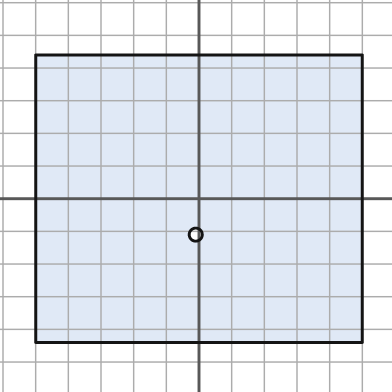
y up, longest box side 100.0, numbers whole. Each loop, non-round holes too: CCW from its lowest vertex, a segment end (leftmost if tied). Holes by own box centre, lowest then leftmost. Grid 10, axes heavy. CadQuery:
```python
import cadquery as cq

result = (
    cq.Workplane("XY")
    .moveTo(-50.0, -44.0)
    .lineTo(50.0, -44.0)
    .lineTo(50.0, 44.0)
    .lineTo(-50.0, 44.0)
    .close()
    .moveTo(-1.0, -11.0)
    .circle(2.0)
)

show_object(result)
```